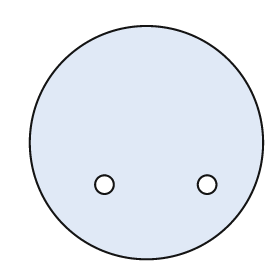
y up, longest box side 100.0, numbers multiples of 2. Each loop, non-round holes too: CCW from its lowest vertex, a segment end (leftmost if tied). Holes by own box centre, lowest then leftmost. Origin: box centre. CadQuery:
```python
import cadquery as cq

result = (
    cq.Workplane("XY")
    .moveTo(0.0, 0.0)
    .circle(50.0)
    .moveTo(-18.0, -18.0)
    .circle(4.0)
    .moveTo(26.0, -18.0)
    .circle(4.0)
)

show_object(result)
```